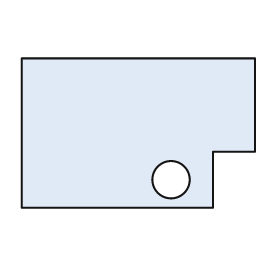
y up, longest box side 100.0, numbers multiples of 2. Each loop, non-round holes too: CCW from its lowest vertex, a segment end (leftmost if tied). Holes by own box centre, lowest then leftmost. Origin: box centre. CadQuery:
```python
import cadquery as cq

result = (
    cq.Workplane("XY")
    .moveTo(-50.0, -32.0)
    .lineTo(32.0, -32.0)
    .lineTo(32.0, -8.0)
    .lineTo(50.0, -8.0)
    .lineTo(50.0, 32.0)
    .lineTo(-50.0, 32.0)
    .close()
    .moveTo(14.0, -20.0)
    .circle(8.0)
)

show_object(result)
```